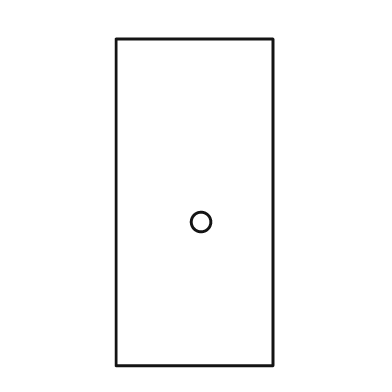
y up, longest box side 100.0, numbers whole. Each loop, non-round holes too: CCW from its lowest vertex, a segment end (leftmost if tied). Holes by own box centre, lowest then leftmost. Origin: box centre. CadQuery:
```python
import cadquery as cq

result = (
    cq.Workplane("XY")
    .moveTo(-24.0, -50.0)
    .lineTo(24.0, -50.0)
    .lineTo(24.0, 50.0)
    .lineTo(-24.0, 50.0)
    .close()
    .moveTo(2.0, -6.0)
    .circle(3.0)
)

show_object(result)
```